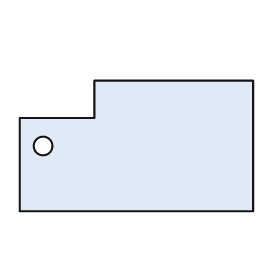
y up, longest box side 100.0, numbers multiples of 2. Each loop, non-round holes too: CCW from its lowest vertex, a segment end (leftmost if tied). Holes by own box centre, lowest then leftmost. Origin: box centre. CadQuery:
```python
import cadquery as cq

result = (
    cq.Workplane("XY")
    .moveTo(-50.0, -28.0)
    .lineTo(50.0, -28.0)
    .lineTo(50.0, 28.0)
    .lineTo(-18.0, 28.0)
    .lineTo(-18.0, 12.0)
    .lineTo(-50.0, 12.0)
    .close()
    .moveTo(-40.0, 0.0)
    .circle(4.0)
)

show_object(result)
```